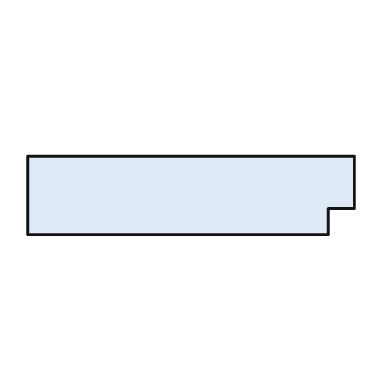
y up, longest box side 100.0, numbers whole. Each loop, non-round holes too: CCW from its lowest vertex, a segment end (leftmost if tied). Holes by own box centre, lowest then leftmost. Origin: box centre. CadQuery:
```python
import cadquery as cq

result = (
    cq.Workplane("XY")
    .moveTo(-50.0, -12.0)
    .lineTo(42.0, -12.0)
    .lineTo(42.0, -4.0)
    .lineTo(50.0, -4.0)
    .lineTo(50.0, 12.0)
    .lineTo(-50.0, 12.0)
    .close()
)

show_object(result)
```